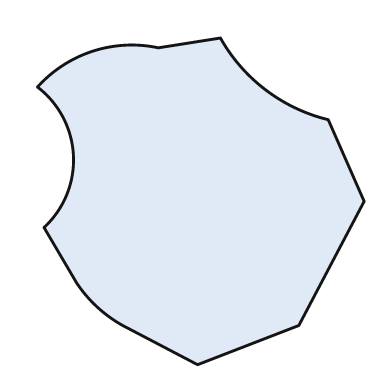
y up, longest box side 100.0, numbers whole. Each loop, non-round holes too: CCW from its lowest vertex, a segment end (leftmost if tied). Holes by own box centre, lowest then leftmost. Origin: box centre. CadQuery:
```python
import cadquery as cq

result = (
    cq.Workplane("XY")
    .moveTo(-1.0, -50.0)
    .lineTo(30.0, -38.0)
    .lineTo(50.0, 0.0)
    .lineTo(39.0, 25.0)
    .threePointArc((20.0, 34.0), (6.0, 50.0))
    .lineTo(-13.0, 47.0)
    .threePointArc((-33.0, 46.0), (-50.0, 35.0))
    .threePointArc((-39.0, 14.0), (-48.0, -8.0))
    .lineTo(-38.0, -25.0)
    .threePointArc((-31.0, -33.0), (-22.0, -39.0))
    .close()
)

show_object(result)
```